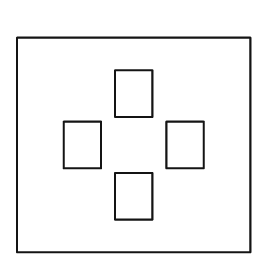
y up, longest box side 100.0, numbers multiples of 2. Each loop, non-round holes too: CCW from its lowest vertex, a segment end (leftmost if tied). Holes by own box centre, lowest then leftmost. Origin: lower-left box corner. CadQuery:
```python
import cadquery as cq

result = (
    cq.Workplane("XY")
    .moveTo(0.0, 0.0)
    .lineTo(100.0, 0.0)
    .lineTo(100.0, 92.0)
    .lineTo(0.0, 92.0)
    .close()
    .moveTo(42.0, 14.0)
    .lineTo(58.0, 14.0)
    .lineTo(58.0, 34.0)
    .lineTo(42.0, 34.0)
    .close()
    .moveTo(20.0, 36.0)
    .lineTo(36.0, 36.0)
    .lineTo(36.0, 56.0)
    .lineTo(20.0, 56.0)
    .close()
    .moveTo(64.0, 36.0)
    .lineTo(80.0, 36.0)
    .lineTo(80.0, 56.0)
    .lineTo(64.0, 56.0)
    .close()
    .moveTo(42.0, 58.0)
    .lineTo(58.0, 58.0)
    .lineTo(58.0, 78.0)
    .lineTo(42.0, 78.0)
    .close()
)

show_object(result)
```